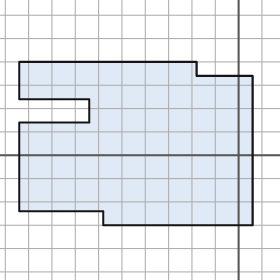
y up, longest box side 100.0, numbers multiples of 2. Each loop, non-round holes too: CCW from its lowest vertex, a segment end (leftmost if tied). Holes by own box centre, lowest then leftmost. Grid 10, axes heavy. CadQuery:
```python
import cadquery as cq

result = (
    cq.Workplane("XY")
    .moveTo(-58.0, -30.0)
    .lineTo(6.0, -30.0)
    .lineTo(6.0, 34.0)
    .lineTo(-18.0, 34.0)
    .lineTo(-18.0, 40.0)
    .lineTo(-94.0, 40.0)
    .lineTo(-94.0, 24.0)
    .lineTo(-64.0, 24.0)
    .lineTo(-64.0, 14.0)
    .lineTo(-94.0, 14.0)
    .lineTo(-94.0, -24.0)
    .lineTo(-58.0, -24.0)
    .close()
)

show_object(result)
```